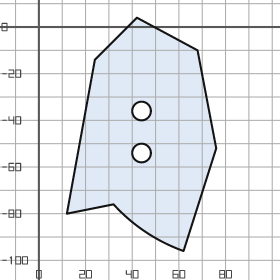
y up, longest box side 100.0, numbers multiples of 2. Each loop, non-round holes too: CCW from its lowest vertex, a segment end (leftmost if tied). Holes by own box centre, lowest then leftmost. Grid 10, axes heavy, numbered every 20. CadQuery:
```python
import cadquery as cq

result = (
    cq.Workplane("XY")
    .moveTo(62.0, -96.0)
    .lineTo(76.0, -52.0)
    .lineTo(68.0, -10.0)
    .lineTo(42.0, 4.0)
    .lineTo(24.0, -14.0)
    .lineTo(12.0, -80.0)
    .lineTo(32.0, -76.0)
    .threePointArc((46.0, -88.0), (62.0, -96.0))
    .close()
    .moveTo(44.0, -54.0)
    .circle(4.0)
    .moveTo(44.0, -36.0)
    .circle(4.0)
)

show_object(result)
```